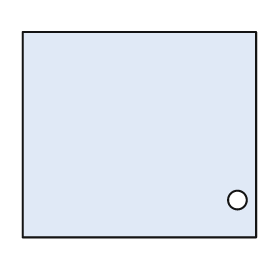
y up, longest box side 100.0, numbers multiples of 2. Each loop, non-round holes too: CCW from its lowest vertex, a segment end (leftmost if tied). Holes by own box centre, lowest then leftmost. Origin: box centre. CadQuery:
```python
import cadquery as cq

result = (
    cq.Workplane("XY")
    .moveTo(-50.0, -44.0)
    .lineTo(50.0, -44.0)
    .lineTo(50.0, 44.0)
    .lineTo(-50.0, 44.0)
    .close()
    .moveTo(42.0, -28.0)
    .circle(4.0)
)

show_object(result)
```